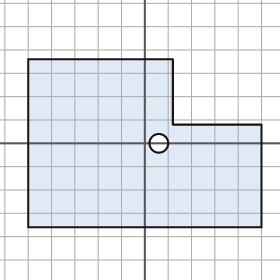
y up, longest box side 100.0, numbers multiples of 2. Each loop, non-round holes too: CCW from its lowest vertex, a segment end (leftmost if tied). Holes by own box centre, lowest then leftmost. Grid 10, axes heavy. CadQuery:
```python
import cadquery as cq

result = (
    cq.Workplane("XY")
    .moveTo(-50.0, -36.0)
    .lineTo(50.0, -36.0)
    .lineTo(50.0, 8.0)
    .lineTo(12.0, 8.0)
    .lineTo(12.0, 36.0)
    .lineTo(-50.0, 36.0)
    .close()
    .moveTo(6.0, 0.0)
    .circle(4.0)
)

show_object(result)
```